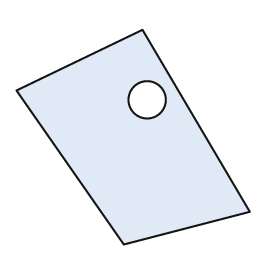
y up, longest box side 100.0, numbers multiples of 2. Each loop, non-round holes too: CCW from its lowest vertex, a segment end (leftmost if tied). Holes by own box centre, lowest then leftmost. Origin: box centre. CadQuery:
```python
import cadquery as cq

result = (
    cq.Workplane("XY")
    .moveTo(-4.0, -46.0)
    .lineTo(50.0, -32.0)
    .lineTo(4.0, 46.0)
    .lineTo(-50.0, 20.0)
    .close()
    .moveTo(6.0, 16.0)
    .circle(8.0)
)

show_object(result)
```